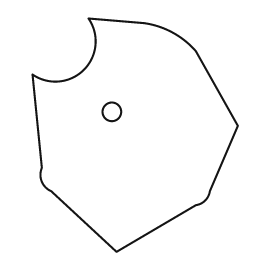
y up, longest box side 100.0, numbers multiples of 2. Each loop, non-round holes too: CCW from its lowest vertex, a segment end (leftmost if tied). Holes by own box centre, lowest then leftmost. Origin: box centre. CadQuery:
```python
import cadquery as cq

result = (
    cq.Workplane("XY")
    .moveTo(-8.0, -50.0)
    .lineTo(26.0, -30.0)
    .threePointArc((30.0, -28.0), (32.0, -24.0))
    .lineTo(44.0, 4.0)
    .lineTo(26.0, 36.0)
    .threePointArc((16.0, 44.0), (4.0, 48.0))
    .lineTo(-20.0, 50.0)
    .threePointArc((-22.0, 28.0), (-44.0, 26.0))
    .lineTo(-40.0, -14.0)
    .threePointArc((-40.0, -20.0), (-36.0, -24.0))
    .close()
    .moveTo(-10.0, 10.0)
    .circle(4.0)
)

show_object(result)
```